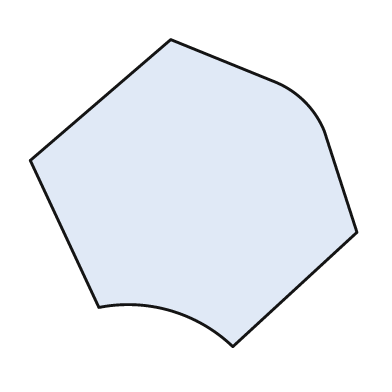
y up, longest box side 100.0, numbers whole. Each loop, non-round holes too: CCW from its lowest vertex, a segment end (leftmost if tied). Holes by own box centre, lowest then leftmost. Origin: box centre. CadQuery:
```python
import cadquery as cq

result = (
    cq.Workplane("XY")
    .moveTo(12.0, -47.0)
    .lineTo(50.0, -12.0)
    .lineTo(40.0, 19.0)
    .threePointArc((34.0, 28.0), (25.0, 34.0))
    .lineTo(-7.0, 47.0)
    .lineTo(-50.0, 10.0)
    .lineTo(-29.0, -35.0)
    .threePointArc((-7.0, -36.0), (12.0, -47.0))
    .close()
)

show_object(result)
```